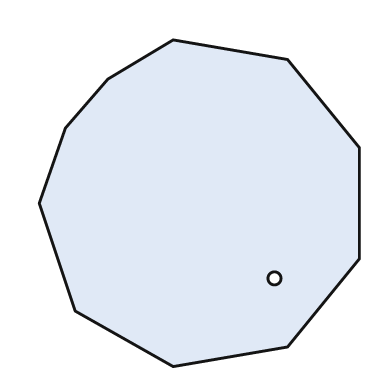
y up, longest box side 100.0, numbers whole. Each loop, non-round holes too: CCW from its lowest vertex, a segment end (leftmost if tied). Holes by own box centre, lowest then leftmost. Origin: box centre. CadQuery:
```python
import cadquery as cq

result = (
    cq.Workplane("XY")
    .moveTo(-8.0, -50.0)
    .lineTo(27.0, -44.0)
    .lineTo(49.0, -17.0)
    .lineTo(49.0, 17.0)
    .lineTo(27.0, 44.0)
    .lineTo(-8.0, 50.0)
    .lineTo(-28.0, 38.0)
    .lineTo(-41.0, 23.0)
    .lineTo(-49.0, 0.0)
    .lineTo(-38.0, -33.0)
    .close()
    .moveTo(23.0, -23.0)
    .circle(2.0)
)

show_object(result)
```